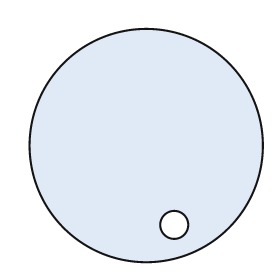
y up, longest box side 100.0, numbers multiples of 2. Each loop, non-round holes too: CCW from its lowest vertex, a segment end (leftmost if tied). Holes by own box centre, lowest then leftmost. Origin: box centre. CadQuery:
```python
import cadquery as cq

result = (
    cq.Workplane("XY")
    .moveTo(0.0, 0.0)
    .circle(50.0)
    .moveTo(12.0, -34.0)
    .circle(6.0)
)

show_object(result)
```